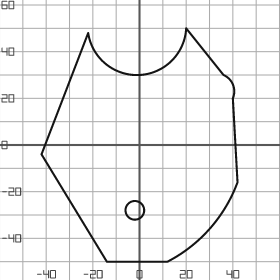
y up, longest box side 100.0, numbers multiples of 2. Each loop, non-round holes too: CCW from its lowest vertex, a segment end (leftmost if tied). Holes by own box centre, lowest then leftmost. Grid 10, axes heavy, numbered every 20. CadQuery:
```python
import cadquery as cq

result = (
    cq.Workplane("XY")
    .moveTo(-14.0, -50.0)
    .lineTo(12.0, -50.0)
    .threePointArc((30.0, -36.0), (42.0, -16.0))
    .lineTo(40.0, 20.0)
    .threePointArc((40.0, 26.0), (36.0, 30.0))
    .lineTo(20.0, 50.0)
    .threePointArc((0.0, 30.0), (-22.0, 48.0))
    .lineTo(-42.0, -4.0)
    .close()
    .moveTo(-2.0, -28.0)
    .circle(4.0)
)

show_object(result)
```